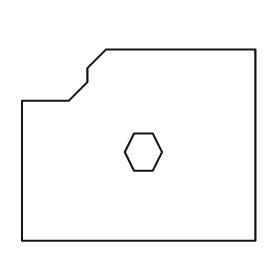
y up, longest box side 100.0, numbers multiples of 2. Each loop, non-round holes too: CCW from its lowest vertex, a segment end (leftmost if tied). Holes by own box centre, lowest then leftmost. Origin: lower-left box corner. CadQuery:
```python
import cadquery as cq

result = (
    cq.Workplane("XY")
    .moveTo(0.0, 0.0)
    .lineTo(100.0, 0.0)
    .lineTo(100.0, 82.0)
    .lineTo(36.0, 82.0)
    .lineTo(28.0, 74.0)
    .lineTo(28.0, 68.0)
    .lineTo(20.0, 60.0)
    .lineTo(0.0, 60.0)
    .close()
    .moveTo(48.0, 30.0)
    .lineTo(56.0, 30.0)
    .lineTo(60.0, 38.0)
    .lineTo(56.0, 46.0)
    .lineTo(48.0, 46.0)
    .lineTo(44.0, 38.0)
    .close()
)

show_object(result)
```